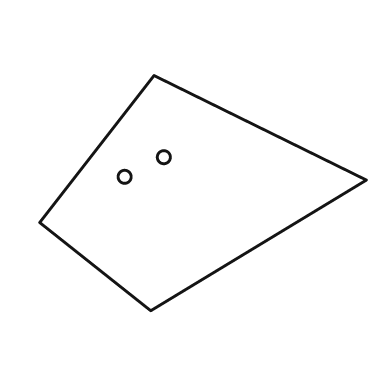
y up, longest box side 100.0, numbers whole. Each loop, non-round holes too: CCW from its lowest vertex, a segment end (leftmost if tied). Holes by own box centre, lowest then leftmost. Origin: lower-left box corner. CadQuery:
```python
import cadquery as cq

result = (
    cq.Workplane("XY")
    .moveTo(34.0, 0.0)
    .lineTo(100.0, 40.0)
    .lineTo(35.0, 72.0)
    .lineTo(0.0, 27.0)
    .close()
    .moveTo(26.0, 41.0)
    .circle(2.0)
    .moveTo(38.0, 47.0)
    .circle(2.0)
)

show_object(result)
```